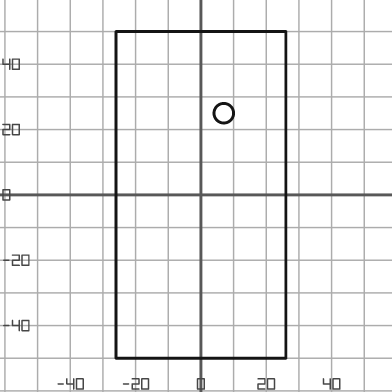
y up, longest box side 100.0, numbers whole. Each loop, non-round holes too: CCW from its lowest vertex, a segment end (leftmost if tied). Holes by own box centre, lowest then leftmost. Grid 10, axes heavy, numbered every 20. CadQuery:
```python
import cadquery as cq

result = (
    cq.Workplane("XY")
    .moveTo(-26.0, -50.0)
    .lineTo(26.0, -50.0)
    .lineTo(26.0, 50.0)
    .lineTo(-26.0, 50.0)
    .close()
    .moveTo(7.0, 25.0)
    .circle(3.0)
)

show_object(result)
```